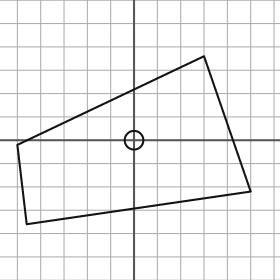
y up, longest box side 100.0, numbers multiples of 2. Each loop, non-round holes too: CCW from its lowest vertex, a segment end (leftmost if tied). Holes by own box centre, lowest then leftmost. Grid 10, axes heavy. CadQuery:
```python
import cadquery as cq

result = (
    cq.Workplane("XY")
    .moveTo(-46.0, -36.0)
    .lineTo(50.0, -22.0)
    .lineTo(30.0, 36.0)
    .lineTo(-50.0, -2.0)
    .close()
    .moveTo(0.0, 0.0)
    .circle(4.0)
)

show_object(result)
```